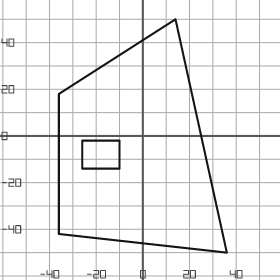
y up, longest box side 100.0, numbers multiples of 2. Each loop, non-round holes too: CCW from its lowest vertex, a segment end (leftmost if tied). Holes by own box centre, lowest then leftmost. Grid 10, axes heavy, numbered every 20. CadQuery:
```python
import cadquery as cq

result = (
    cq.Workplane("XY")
    .moveTo(36.0, -50.0)
    .lineTo(14.0, 50.0)
    .lineTo(-36.0, 18.0)
    .lineTo(-36.0, -42.0)
    .close()
    .moveTo(-26.0, -14.0)
    .lineTo(-10.0, -14.0)
    .lineTo(-10.0, -2.0)
    .lineTo(-26.0, -2.0)
    .close()
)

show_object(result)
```